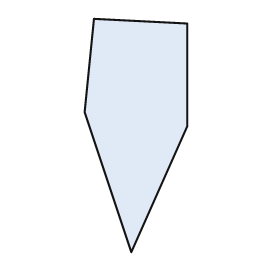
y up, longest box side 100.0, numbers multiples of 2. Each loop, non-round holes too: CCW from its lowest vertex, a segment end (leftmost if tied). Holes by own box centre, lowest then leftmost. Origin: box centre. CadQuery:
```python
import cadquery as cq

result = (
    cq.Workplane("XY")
    .moveTo(-2.0, -50.0)
    .lineTo(22.0, 4.0)
    .lineTo(22.0, 48.0)
    .lineTo(-18.0, 50.0)
    .lineTo(-22.0, 10.0)
    .close()
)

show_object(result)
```